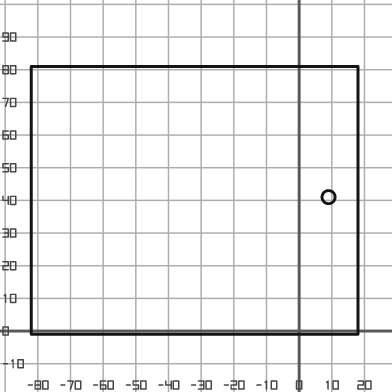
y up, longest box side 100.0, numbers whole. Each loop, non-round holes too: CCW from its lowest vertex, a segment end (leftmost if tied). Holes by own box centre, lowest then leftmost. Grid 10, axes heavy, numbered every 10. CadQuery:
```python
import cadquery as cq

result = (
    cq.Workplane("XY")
    .moveTo(-82.0, -1.0)
    .lineTo(18.0, -1.0)
    .lineTo(18.0, 81.0)
    .lineTo(-82.0, 81.0)
    .close()
    .moveTo(9.0, 41.0)
    .circle(2.0)
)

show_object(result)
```